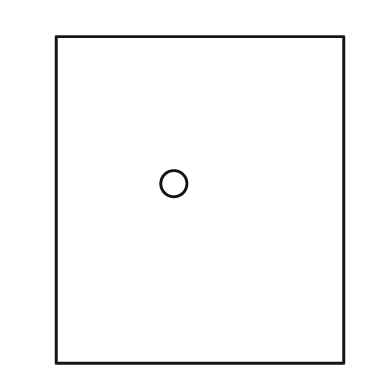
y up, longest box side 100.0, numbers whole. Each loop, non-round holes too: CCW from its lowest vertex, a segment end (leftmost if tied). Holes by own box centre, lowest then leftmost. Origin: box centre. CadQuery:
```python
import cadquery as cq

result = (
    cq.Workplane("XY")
    .moveTo(-44.0, -50.0)
    .lineTo(44.0, -50.0)
    .lineTo(44.0, 50.0)
    .lineTo(-44.0, 50.0)
    .close()
    .moveTo(-8.0, 5.0)
    .circle(4.0)
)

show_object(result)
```